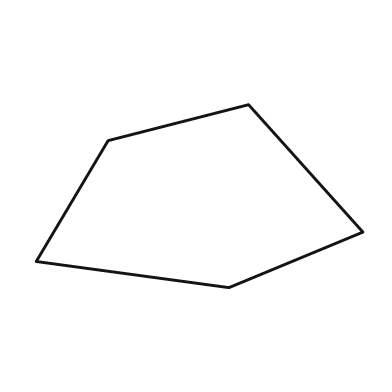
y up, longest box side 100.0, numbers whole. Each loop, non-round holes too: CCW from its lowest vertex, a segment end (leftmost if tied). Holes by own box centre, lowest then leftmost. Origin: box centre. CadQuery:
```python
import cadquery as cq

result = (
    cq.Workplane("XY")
    .moveTo(9.0, -28.0)
    .lineTo(50.0, -11.0)
    .lineTo(15.0, 28.0)
    .lineTo(-28.0, 17.0)
    .lineTo(-50.0, -20.0)
    .close()
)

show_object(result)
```